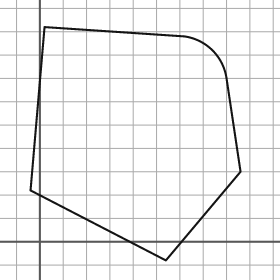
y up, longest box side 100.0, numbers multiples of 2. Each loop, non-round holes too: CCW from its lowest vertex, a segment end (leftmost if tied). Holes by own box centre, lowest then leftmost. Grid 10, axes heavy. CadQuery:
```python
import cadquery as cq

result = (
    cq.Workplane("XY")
    .moveTo(54.0, -8.0)
    .lineTo(86.0, 30.0)
    .lineTo(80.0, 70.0)
    .threePointArc((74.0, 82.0), (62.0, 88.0))
    .lineTo(2.0, 92.0)
    .lineTo(-4.0, 22.0)
    .close()
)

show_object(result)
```